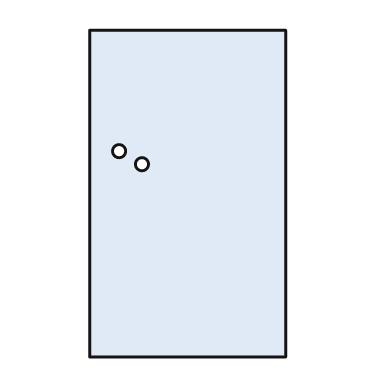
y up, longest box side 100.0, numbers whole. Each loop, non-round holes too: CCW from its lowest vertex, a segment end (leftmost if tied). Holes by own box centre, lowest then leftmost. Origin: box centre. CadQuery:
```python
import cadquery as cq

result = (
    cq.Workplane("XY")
    .moveTo(-30.0, -50.0)
    .lineTo(30.0, -50.0)
    .lineTo(30.0, 50.0)
    .lineTo(-30.0, 50.0)
    .close()
    .moveTo(-14.0, 9.0)
    .circle(2.0)
    .moveTo(-21.0, 13.0)
    .circle(2.0)
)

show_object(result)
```